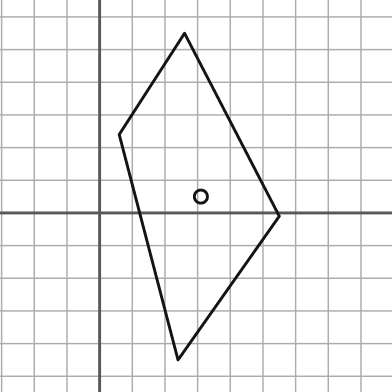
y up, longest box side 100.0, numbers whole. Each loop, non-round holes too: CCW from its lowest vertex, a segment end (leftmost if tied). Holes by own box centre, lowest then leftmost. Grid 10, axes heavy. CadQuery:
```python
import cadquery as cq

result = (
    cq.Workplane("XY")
    .moveTo(24.0, -45.0)
    .lineTo(55.0, -1.0)
    .lineTo(26.0, 55.0)
    .lineTo(6.0, 24.0)
    .close()
    .moveTo(31.0, 5.0)
    .circle(2.0)
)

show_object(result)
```